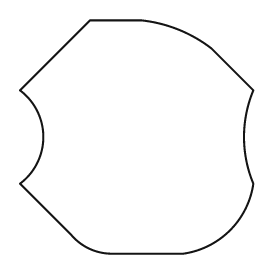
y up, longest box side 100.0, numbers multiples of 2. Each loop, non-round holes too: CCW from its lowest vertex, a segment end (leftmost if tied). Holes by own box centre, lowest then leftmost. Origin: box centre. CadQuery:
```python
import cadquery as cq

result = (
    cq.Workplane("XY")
    .moveTo(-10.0, -50.0)
    .lineTo(20.0, -50.0)
    .threePointArc((40.0, -40.0), (50.0, -20.0))
    .threePointArc((46.0, 0.0), (50.0, 20.0))
    .lineTo(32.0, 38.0)
    .threePointArc((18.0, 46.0), (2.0, 50.0))
    .lineTo(-20.0, 50.0)
    .lineTo(-50.0, 20.0)
    .threePointArc((-40.0, 0.0), (-50.0, -20.0))
    .lineTo(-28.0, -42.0)
    .threePointArc((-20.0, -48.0), (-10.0, -50.0))
    .close()
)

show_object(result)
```